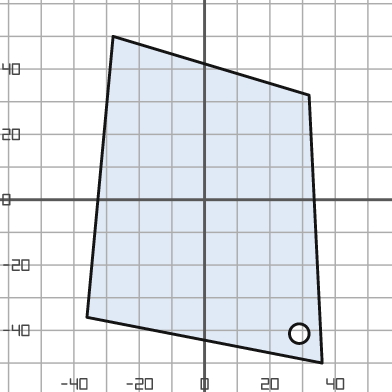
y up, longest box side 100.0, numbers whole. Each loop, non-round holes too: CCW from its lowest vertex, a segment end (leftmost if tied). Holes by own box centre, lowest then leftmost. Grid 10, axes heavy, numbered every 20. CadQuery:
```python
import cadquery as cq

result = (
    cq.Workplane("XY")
    .moveTo(36.0, -50.0)
    .lineTo(32.0, 32.0)
    .lineTo(-28.0, 50.0)
    .lineTo(-36.0, -36.0)
    .close()
    .moveTo(29.0, -41.0)
    .circle(3.0)
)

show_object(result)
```